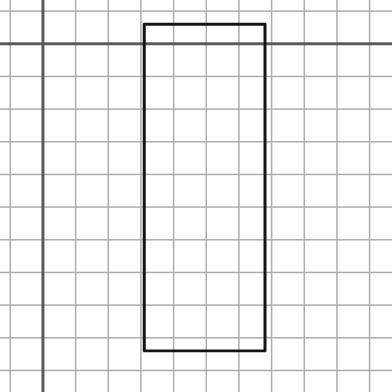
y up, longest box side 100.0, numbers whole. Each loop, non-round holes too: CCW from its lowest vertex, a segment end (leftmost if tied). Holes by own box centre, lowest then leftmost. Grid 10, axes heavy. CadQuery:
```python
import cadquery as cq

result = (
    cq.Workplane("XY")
    .moveTo(31.0, -94.0)
    .lineTo(68.0, -94.0)
    .lineTo(68.0, 6.0)
    .lineTo(31.0, 6.0)
    .close()
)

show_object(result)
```